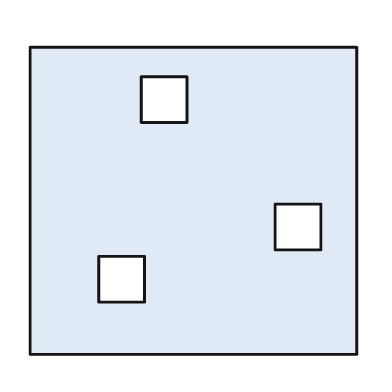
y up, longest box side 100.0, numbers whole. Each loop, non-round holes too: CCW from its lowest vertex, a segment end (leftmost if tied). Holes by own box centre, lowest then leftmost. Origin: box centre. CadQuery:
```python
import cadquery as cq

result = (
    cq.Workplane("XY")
    .moveTo(-50.0, -47.0)
    .lineTo(50.0, -47.0)
    .lineTo(50.0, 47.0)
    .lineTo(-50.0, 47.0)
    .close()
    .moveTo(-29.0, -31.0)
    .lineTo(-15.0, -31.0)
    .lineTo(-15.0, -17.0)
    .lineTo(-29.0, -17.0)
    .close()
    .moveTo(25.0, -15.0)
    .lineTo(39.0, -15.0)
    .lineTo(39.0, -1.0)
    .lineTo(25.0, -1.0)
    .close()
    .moveTo(-16.0, 24.0)
    .lineTo(-2.0, 24.0)
    .lineTo(-2.0, 38.0)
    .lineTo(-16.0, 38.0)
    .close()
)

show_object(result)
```